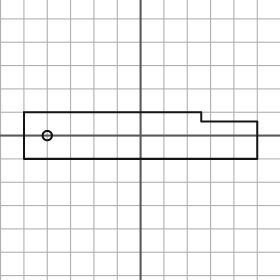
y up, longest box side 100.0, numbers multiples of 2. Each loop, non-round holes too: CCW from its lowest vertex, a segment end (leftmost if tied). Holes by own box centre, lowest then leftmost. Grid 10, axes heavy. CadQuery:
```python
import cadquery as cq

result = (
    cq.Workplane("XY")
    .moveTo(-50.0, -10.0)
    .lineTo(50.0, -10.0)
    .lineTo(50.0, 6.0)
    .lineTo(26.0, 6.0)
    .lineTo(26.0, 10.0)
    .lineTo(-50.0, 10.0)
    .close()
    .moveTo(-40.0, 0.0)
    .circle(2.0)
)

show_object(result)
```